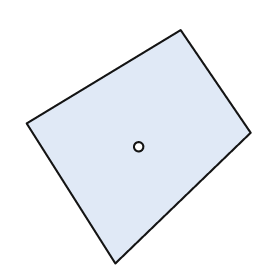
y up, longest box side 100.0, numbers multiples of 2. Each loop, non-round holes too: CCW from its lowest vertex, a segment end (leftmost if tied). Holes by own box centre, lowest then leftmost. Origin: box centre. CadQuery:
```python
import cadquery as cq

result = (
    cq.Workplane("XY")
    .moveTo(-10.0, -50.0)
    .lineTo(48.0, 6.0)
    .lineTo(18.0, 50.0)
    .lineTo(-48.0, 10.0)
    .close()
    .moveTo(0.0, 0.0)
    .circle(2.0)
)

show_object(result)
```